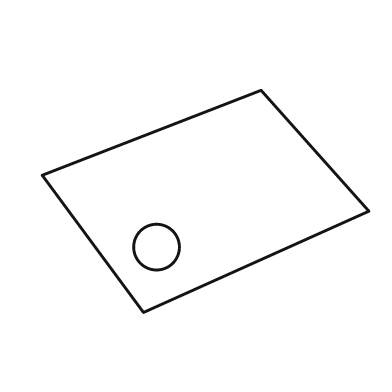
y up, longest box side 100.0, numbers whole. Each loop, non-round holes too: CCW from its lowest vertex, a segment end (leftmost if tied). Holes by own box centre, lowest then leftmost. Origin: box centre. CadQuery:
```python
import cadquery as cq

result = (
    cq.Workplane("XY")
    .moveTo(-19.0, -34.0)
    .lineTo(50.0, -3.0)
    .lineTo(17.0, 34.0)
    .lineTo(-50.0, 8.0)
    .close()
    .moveTo(-15.0, -14.0)
    .circle(7.0)
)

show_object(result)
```